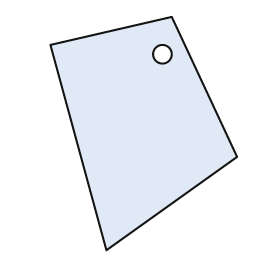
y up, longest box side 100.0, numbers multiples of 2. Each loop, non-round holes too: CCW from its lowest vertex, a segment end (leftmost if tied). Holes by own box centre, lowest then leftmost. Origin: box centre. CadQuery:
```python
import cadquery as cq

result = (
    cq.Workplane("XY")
    .moveTo(-16.0, -50.0)
    .lineTo(40.0, -10.0)
    .lineTo(12.0, 50.0)
    .lineTo(-40.0, 38.0)
    .close()
    .moveTo(8.0, 34.0)
    .circle(4.0)
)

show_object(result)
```